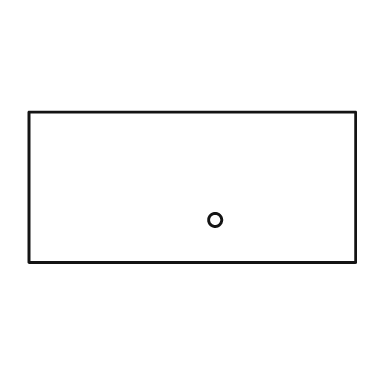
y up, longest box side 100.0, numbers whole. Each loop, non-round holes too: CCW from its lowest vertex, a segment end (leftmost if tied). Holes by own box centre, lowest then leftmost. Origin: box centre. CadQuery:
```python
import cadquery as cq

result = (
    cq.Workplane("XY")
    .moveTo(-50.0, -23.0)
    .lineTo(50.0, -23.0)
    .lineTo(50.0, 23.0)
    .lineTo(-50.0, 23.0)
    .close()
    .moveTo(7.0, -10.0)
    .circle(2.0)
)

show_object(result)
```